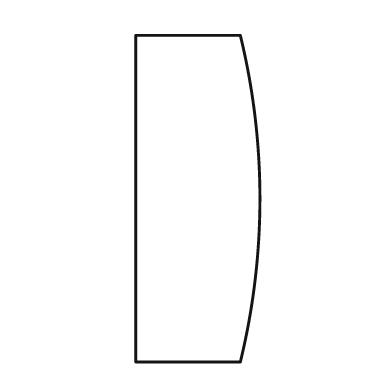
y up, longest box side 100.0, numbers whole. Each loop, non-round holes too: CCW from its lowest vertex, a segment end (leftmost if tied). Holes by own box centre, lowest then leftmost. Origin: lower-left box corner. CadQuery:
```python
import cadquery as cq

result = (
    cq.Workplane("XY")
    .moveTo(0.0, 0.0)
    .lineTo(32.0, 0.0)
    .threePointArc((38.0, 50.0), (32.0, 100.0))
    .lineTo(0.0, 100.0)
    .close()
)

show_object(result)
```